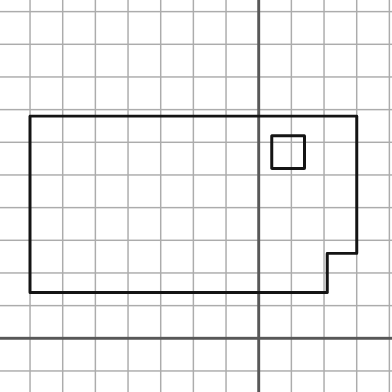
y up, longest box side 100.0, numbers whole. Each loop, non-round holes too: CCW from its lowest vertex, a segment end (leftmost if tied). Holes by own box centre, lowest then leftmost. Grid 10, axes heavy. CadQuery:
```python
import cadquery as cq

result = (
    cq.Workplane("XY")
    .moveTo(-70.0, 14.0)
    .lineTo(21.0, 14.0)
    .lineTo(21.0, 26.0)
    .lineTo(30.0, 26.0)
    .lineTo(30.0, 68.0)
    .lineTo(-70.0, 68.0)
    .close()
    .moveTo(4.0, 52.0)
    .lineTo(14.0, 52.0)
    .lineTo(14.0, 62.0)
    .lineTo(4.0, 62.0)
    .close()
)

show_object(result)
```